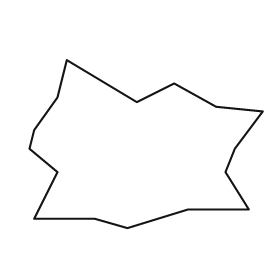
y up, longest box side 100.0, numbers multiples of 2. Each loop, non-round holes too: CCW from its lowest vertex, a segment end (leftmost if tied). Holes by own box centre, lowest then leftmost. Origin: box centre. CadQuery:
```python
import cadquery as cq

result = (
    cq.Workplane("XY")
    .moveTo(-8.0, -36.0)
    .lineTo(18.0, -28.0)
    .lineTo(44.0, -28.0)
    .lineTo(34.0, -12.0)
    .lineTo(38.0, -2.0)
    .lineTo(50.0, 14.0)
    .lineTo(30.0, 16.0)
    .lineTo(12.0, 26.0)
    .lineTo(-4.0, 18.0)
    .lineTo(-34.0, 36.0)
    .lineTo(-38.0, 20.0)
    .lineTo(-48.0, 6.0)
    .lineTo(-50.0, -2.0)
    .lineTo(-38.0, -12.0)
    .lineTo(-48.0, -32.0)
    .lineTo(-22.0, -32.0)
    .close()
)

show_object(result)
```